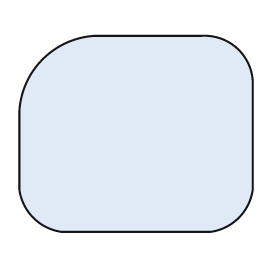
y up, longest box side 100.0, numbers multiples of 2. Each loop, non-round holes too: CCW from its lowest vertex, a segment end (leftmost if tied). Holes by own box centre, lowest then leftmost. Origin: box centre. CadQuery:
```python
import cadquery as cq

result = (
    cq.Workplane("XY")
    .moveTo(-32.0, -42.0)
    .lineTo(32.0, -42.0)
    .threePointArc((44.0, -36.0), (50.0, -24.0))
    .lineTo(50.0, 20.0)
    .threePointArc((44.0, 36.0), (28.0, 42.0))
    .lineTo(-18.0, 42.0)
    .threePointArc((-40.0, 32.0), (-50.0, 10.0))
    .lineTo(-50.0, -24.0)
    .threePointArc((-44.0, -36.0), (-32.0, -42.0))
    .close()
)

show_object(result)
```